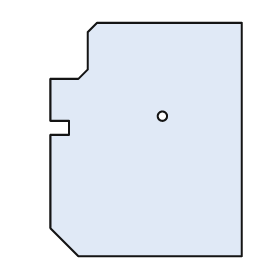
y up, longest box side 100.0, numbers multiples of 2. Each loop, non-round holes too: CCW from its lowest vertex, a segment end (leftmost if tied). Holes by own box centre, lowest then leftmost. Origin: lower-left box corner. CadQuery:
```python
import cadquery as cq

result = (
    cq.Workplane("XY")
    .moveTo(12.0, 0.0)
    .lineTo(82.0, 0.0)
    .lineTo(82.0, 100.0)
    .lineTo(20.0, 100.0)
    .lineTo(16.0, 96.0)
    .lineTo(16.0, 80.0)
    .lineTo(12.0, 76.0)
    .lineTo(0.0, 76.0)
    .lineTo(0.0, 58.0)
    .lineTo(8.0, 58.0)
    .lineTo(8.0, 52.0)
    .lineTo(0.0, 52.0)
    .lineTo(0.0, 12.0)
    .close()
    .moveTo(48.0, 60.0)
    .circle(2.0)
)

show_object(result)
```